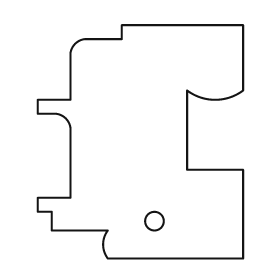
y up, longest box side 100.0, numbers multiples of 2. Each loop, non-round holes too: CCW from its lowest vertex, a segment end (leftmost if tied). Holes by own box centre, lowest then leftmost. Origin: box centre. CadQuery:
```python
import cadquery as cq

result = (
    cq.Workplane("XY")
    .moveTo(-14.0, -50.0)
    .lineTo(44.0, -50.0)
    .lineTo(44.0, -12.0)
    .lineTo(20.0, -12.0)
    .lineTo(20.0, 22.0)
    .threePointArc((32.0, 18.0), (44.0, 22.0))
    .lineTo(44.0, 50.0)
    .lineTo(-8.0, 50.0)
    .lineTo(-8.0, 44.0)
    .lineTo(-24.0, 44.0)
    .threePointArc((-28.0, 42.0), (-30.0, 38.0))
    .lineTo(-30.0, 18.0)
    .lineTo(-44.0, 18.0)
    .lineTo(-44.0, 12.0)
    .lineTo(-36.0, 12.0)
    .threePointArc((-32.0, 10.0), (-30.0, 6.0))
    .lineTo(-30.0, -24.0)
    .lineTo(-44.0, -24.0)
    .lineTo(-44.0, -30.0)
    .lineTo(-38.0, -30.0)
    .lineTo(-38.0, -38.0)
    .lineTo(-14.0, -38.0)
    .threePointArc((-16.0, -44.0), (-14.0, -50.0))
    .close()
    .moveTo(6.0, -34.0)
    .circle(4.0)
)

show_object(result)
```